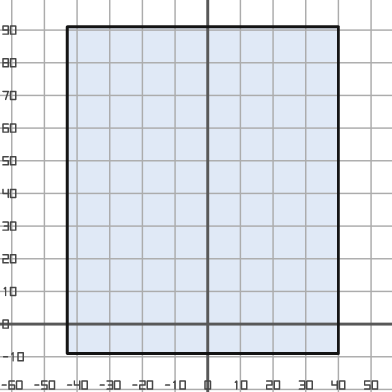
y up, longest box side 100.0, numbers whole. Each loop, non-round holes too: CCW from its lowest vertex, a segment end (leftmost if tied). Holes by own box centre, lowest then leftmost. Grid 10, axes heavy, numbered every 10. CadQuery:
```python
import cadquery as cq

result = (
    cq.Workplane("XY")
    .moveTo(-43.0, -9.0)
    .lineTo(40.0, -9.0)
    .lineTo(40.0, 91.0)
    .lineTo(-43.0, 91.0)
    .close()
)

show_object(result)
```